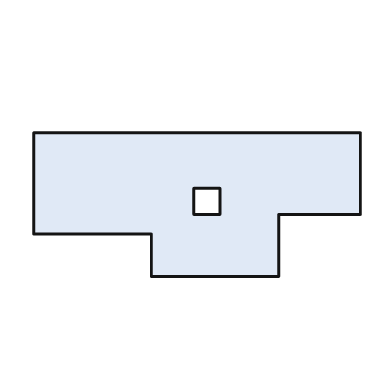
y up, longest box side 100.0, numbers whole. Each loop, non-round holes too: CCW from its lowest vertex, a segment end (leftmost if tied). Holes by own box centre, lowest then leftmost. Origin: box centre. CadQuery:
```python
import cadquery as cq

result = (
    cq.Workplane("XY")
    .moveTo(-14.0, -22.0)
    .lineTo(25.0, -22.0)
    .lineTo(25.0, -3.0)
    .lineTo(50.0, -3.0)
    .lineTo(50.0, 22.0)
    .lineTo(-50.0, 22.0)
    .lineTo(-50.0, -9.0)
    .lineTo(-14.0, -9.0)
    .close()
    .moveTo(-1.0, -3.0)
    .lineTo(7.0, -3.0)
    .lineTo(7.0, 5.0)
    .lineTo(-1.0, 5.0)
    .close()
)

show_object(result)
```